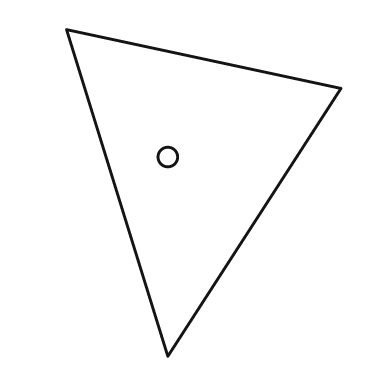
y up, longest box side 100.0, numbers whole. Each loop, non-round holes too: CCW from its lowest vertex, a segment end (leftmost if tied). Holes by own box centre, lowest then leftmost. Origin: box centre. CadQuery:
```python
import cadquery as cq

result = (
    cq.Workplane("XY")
    .moveTo(-11.0, -50.0)
    .lineTo(42.0, 32.0)
    .lineTo(-42.0, 50.0)
    .close()
    .moveTo(-11.0, 11.0)
    .circle(3.0)
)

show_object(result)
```